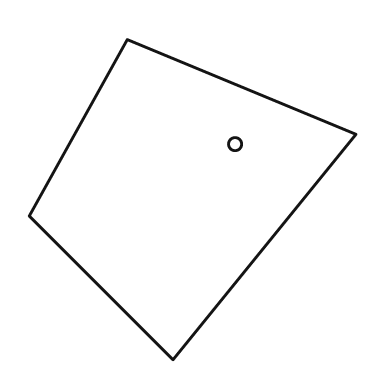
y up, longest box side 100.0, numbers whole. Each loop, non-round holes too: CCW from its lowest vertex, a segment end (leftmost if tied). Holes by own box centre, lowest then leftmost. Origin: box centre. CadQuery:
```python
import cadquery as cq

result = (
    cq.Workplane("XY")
    .moveTo(-6.0, -49.0)
    .lineTo(50.0, 20.0)
    .lineTo(-20.0, 49.0)
    .lineTo(-50.0, -5.0)
    .close()
    .moveTo(13.0, 17.0)
    .circle(2.0)
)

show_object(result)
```